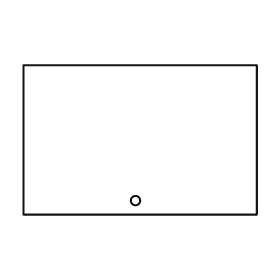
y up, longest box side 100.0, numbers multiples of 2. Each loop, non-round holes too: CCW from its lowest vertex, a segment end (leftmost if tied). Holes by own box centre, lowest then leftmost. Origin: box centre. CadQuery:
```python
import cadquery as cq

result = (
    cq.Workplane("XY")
    .moveTo(-50.0, -32.0)
    .lineTo(50.0, -32.0)
    .lineTo(50.0, 32.0)
    .lineTo(-50.0, 32.0)
    .close()
    .moveTo(-2.0, -26.0)
    .circle(2.0)
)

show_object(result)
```